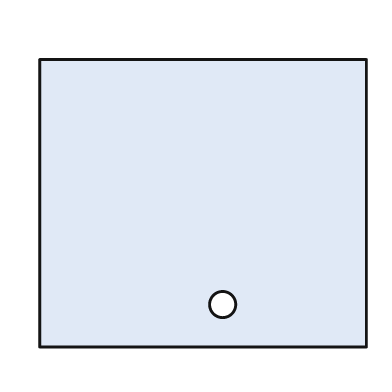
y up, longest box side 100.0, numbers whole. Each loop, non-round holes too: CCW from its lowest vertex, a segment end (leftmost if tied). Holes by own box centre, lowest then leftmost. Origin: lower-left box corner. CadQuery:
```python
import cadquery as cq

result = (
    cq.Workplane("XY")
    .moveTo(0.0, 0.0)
    .lineTo(100.0, 0.0)
    .lineTo(100.0, 88.0)
    .lineTo(0.0, 88.0)
    .close()
    .moveTo(56.0, 13.0)
    .circle(4.0)
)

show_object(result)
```